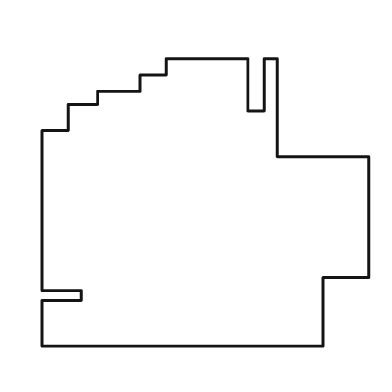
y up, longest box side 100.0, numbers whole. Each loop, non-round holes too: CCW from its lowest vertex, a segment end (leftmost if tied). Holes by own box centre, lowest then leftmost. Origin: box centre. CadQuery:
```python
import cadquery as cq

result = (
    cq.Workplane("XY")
    .moveTo(-50.0, -44.0)
    .lineTo(36.0, -44.0)
    .lineTo(36.0, -23.0)
    .lineTo(50.0, -23.0)
    .lineTo(50.0, 14.0)
    .lineTo(22.0, 14.0)
    .lineTo(22.0, 44.0)
    .lineTo(18.0, 44.0)
    .lineTo(18.0, 28.0)
    .lineTo(13.0, 28.0)
    .lineTo(13.0, 44.0)
    .lineTo(-12.0, 44.0)
    .lineTo(-12.0, 39.0)
    .lineTo(-20.0, 39.0)
    .lineTo(-20.0, 34.0)
    .lineTo(-33.0, 34.0)
    .lineTo(-33.0, 30.0)
    .lineTo(-42.0, 30.0)
    .lineTo(-42.0, 22.0)
    .lineTo(-50.0, 22.0)
    .lineTo(-50.0, -27.0)
    .lineTo(-38.0, -27.0)
    .lineTo(-38.0, -30.0)
    .lineTo(-50.0, -30.0)
    .close()
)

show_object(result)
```